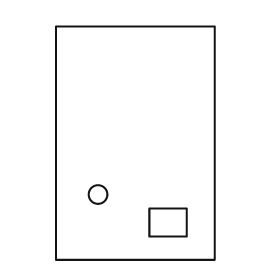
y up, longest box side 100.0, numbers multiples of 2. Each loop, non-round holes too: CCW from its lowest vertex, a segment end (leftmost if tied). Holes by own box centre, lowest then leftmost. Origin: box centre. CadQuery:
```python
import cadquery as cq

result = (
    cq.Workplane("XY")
    .moveTo(-34.0, -50.0)
    .lineTo(34.0, -50.0)
    .lineTo(34.0, 50.0)
    .lineTo(-34.0, 50.0)
    .close()
    .moveTo(6.0, -40.0)
    .lineTo(22.0, -40.0)
    .lineTo(22.0, -28.0)
    .lineTo(6.0, -28.0)
    .close()
    .moveTo(-16.0, -22.0)
    .circle(4.0)
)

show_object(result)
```